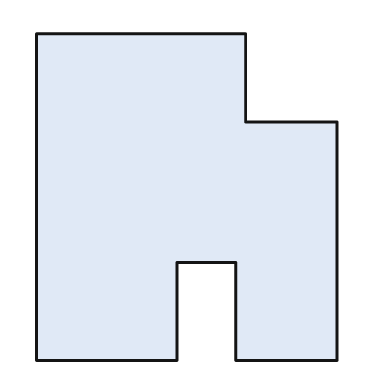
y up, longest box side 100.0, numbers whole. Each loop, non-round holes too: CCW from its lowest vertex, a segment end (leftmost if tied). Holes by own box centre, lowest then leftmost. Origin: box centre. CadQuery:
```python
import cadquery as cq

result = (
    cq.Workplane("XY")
    .moveTo(-46.0, -50.0)
    .lineTo(-3.0, -50.0)
    .lineTo(-3.0, -20.0)
    .lineTo(15.0, -20.0)
    .lineTo(15.0, -50.0)
    .lineTo(46.0, -50.0)
    .lineTo(46.0, 23.0)
    .lineTo(18.0, 23.0)
    .lineTo(18.0, 50.0)
    .lineTo(-46.0, 50.0)
    .close()
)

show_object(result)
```